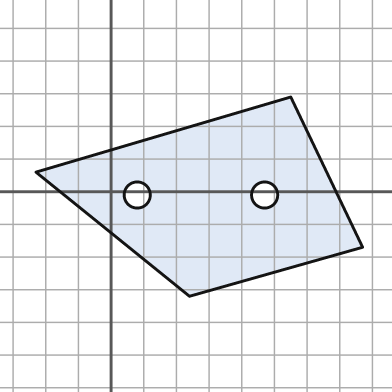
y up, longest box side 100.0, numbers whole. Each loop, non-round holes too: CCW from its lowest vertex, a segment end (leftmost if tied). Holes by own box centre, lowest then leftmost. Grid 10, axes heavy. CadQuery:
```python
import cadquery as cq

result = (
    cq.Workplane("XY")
    .moveTo(24.0, -32.0)
    .lineTo(77.0, -17.0)
    .lineTo(55.0, 29.0)
    .lineTo(-23.0, 6.0)
    .close()
    .moveTo(8.0, -1.0)
    .circle(4.0)
    .moveTo(47.0, -1.0)
    .circle(4.0)
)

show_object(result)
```